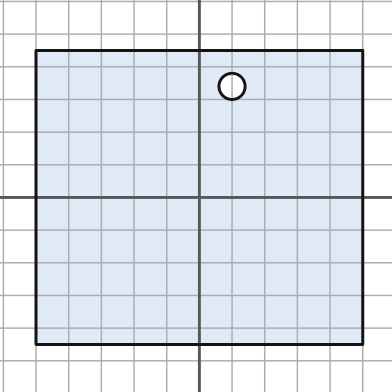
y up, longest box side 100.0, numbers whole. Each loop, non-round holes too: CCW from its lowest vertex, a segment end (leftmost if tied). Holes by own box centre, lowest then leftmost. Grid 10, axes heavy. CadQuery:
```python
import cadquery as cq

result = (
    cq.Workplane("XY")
    .moveTo(-50.0, -45.0)
    .lineTo(50.0, -45.0)
    .lineTo(50.0, 45.0)
    .lineTo(-50.0, 45.0)
    .close()
    .moveTo(10.0, 34.0)
    .circle(4.0)
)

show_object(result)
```